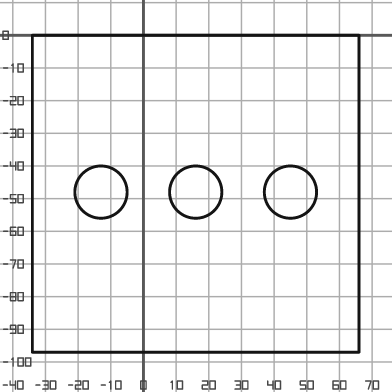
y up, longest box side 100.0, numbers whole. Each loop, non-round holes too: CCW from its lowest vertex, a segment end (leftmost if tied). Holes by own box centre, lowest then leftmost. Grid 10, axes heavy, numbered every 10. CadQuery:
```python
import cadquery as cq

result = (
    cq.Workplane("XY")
    .moveTo(-34.0, -97.0)
    .lineTo(66.0, -97.0)
    .lineTo(66.0, 0.0)
    .lineTo(-34.0, 0.0)
    .close()
    .moveTo(-13.0, -48.0)
    .circle(8.0)
    .moveTo(16.0, -48.0)
    .circle(8.0)
    .moveTo(45.0, -48.0)
    .circle(8.0)
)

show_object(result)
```